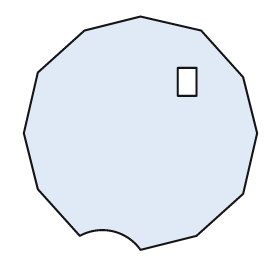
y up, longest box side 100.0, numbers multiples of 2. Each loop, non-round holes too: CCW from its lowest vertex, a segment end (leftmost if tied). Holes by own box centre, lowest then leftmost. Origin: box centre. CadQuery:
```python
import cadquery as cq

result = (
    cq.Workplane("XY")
    .moveTo(0.0, -50.0)
    .lineTo(24.0, -44.0)
    .lineTo(44.0, -26.0)
    .lineTo(50.0, 0.0)
    .lineTo(44.0, 24.0)
    .lineTo(26.0, 44.0)
    .lineTo(0.0, 50.0)
    .lineTo(-24.0, 44.0)
    .lineTo(-44.0, 26.0)
    .lineTo(-50.0, 0.0)
    .lineTo(-44.0, -24.0)
    .lineTo(-26.0, -44.0)
    .threePointArc((-12.0, -42.0), (0.0, -50.0))
    .close()
    .moveTo(16.0, 16.0)
    .lineTo(24.0, 16.0)
    .lineTo(24.0, 28.0)
    .lineTo(16.0, 28.0)
    .close()
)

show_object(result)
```